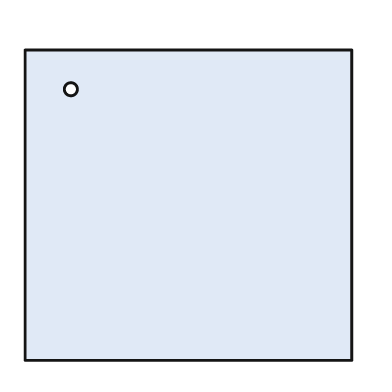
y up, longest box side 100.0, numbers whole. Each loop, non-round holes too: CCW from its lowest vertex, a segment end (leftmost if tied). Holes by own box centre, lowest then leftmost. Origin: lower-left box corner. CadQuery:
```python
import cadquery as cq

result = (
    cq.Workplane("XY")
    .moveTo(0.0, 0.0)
    .lineTo(100.0, 0.0)
    .lineTo(100.0, 95.0)
    .lineTo(0.0, 95.0)
    .close()
    .moveTo(14.0, 83.0)
    .circle(2.0)
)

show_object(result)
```